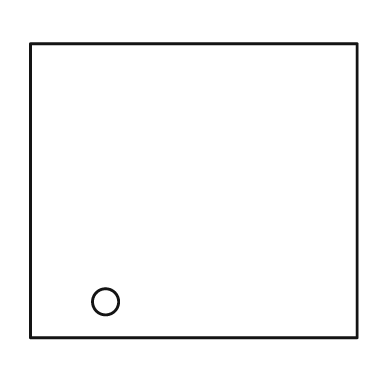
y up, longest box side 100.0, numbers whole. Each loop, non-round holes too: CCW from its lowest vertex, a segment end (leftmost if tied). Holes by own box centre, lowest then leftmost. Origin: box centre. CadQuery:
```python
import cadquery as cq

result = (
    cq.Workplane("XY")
    .moveTo(-50.0, -45.0)
    .lineTo(50.0, -45.0)
    .lineTo(50.0, 45.0)
    .lineTo(-50.0, 45.0)
    .close()
    .moveTo(-27.0, -34.0)
    .circle(4.0)
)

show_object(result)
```